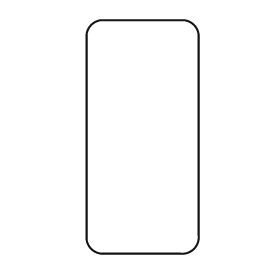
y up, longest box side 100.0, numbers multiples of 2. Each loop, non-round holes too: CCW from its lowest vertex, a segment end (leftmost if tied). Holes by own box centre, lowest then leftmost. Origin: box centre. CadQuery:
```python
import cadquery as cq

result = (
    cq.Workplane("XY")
    .moveTo(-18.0, -50.0)
    .lineTo(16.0, -50.0)
    .threePointArc((22.0, -48.0), (24.0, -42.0))
    .lineTo(24.0, 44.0)
    .threePointArc((22.0, 48.0), (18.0, 50.0))
    .lineTo(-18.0, 50.0)
    .threePointArc((-22.0, 48.0), (-24.0, 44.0))
    .lineTo(-24.0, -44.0)
    .threePointArc((-22.0, -48.0), (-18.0, -50.0))
    .close()
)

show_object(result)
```